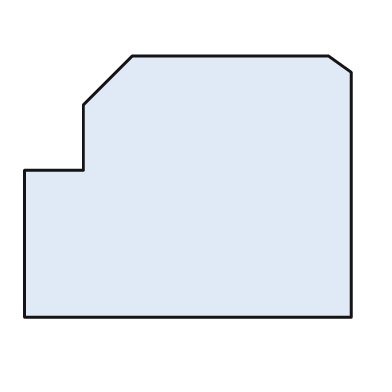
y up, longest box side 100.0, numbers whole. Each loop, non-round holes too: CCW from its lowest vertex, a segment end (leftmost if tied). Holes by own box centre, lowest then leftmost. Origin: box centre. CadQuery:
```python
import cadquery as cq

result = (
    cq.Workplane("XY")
    .moveTo(-50.0, -40.0)
    .lineTo(50.0, -40.0)
    .lineTo(50.0, 35.0)
    .lineTo(43.0, 40.0)
    .lineTo(-17.0, 40.0)
    .lineTo(-32.0, 25.0)
    .lineTo(-32.0, 5.0)
    .lineTo(-50.0, 5.0)
    .close()
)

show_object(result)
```